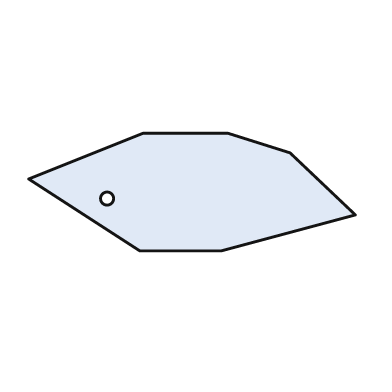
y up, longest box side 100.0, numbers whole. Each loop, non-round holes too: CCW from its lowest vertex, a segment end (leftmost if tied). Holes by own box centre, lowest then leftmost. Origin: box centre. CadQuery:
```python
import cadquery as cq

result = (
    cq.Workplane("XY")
    .moveTo(-16.0, -18.0)
    .lineTo(9.0, -18.0)
    .lineTo(50.0, -7.0)
    .lineTo(30.0, 12.0)
    .lineTo(11.0, 18.0)
    .lineTo(-15.0, 18.0)
    .lineTo(-50.0, 4.0)
    .close()
    .moveTo(-26.0, -2.0)
    .circle(2.0)
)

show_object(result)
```